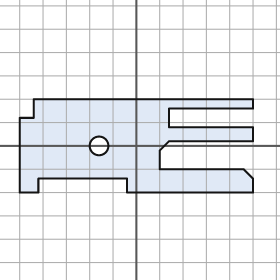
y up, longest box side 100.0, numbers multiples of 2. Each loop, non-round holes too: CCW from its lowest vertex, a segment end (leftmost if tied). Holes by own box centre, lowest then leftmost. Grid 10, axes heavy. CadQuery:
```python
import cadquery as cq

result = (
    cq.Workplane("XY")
    .moveTo(-50.0, -20.0)
    .lineTo(-42.0, -20.0)
    .lineTo(-42.0, -14.0)
    .lineTo(-4.0, -14.0)
    .lineTo(-4.0, -20.0)
    .lineTo(50.0, -20.0)
    .lineTo(50.0, -14.0)
    .lineTo(46.0, -10.0)
    .lineTo(10.0, -10.0)
    .lineTo(10.0, -2.0)
    .lineTo(14.0, 2.0)
    .lineTo(50.0, 2.0)
    .lineTo(50.0, 8.0)
    .lineTo(14.0, 8.0)
    .lineTo(14.0, 16.0)
    .lineTo(50.0, 16.0)
    .lineTo(50.0, 20.0)
    .lineTo(-44.0, 20.0)
    .lineTo(-44.0, 12.0)
    .lineTo(-50.0, 12.0)
    .close()
    .moveTo(-16.0, 0.0)
    .circle(4.0)
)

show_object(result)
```